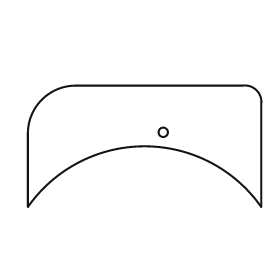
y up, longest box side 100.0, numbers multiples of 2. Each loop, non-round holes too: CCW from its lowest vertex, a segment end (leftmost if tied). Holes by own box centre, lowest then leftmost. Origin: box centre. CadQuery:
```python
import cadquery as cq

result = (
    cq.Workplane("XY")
    .moveTo(-50.0, -26.0)
    .threePointArc((0.0, 0.0), (50.0, -26.0))
    .lineTo(50.0, 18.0)
    .threePointArc((48.0, 24.0), (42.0, 26.0))
    .lineTo(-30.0, 26.0)
    .threePointArc((-44.0, 20.0), (-50.0, 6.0))
    .close()
    .moveTo(8.0, 6.0)
    .circle(2.0)
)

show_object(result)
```